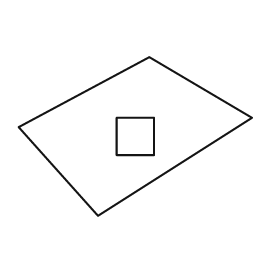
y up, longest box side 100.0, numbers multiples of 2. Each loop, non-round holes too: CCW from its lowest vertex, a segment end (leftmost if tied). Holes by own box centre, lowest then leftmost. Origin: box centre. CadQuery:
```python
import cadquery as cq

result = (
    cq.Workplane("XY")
    .moveTo(-16.0, -34.0)
    .lineTo(50.0, 8.0)
    .lineTo(6.0, 34.0)
    .lineTo(-50.0, 4.0)
    .close()
    .moveTo(-8.0, -8.0)
    .lineTo(8.0, -8.0)
    .lineTo(8.0, 8.0)
    .lineTo(-8.0, 8.0)
    .close()
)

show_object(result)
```